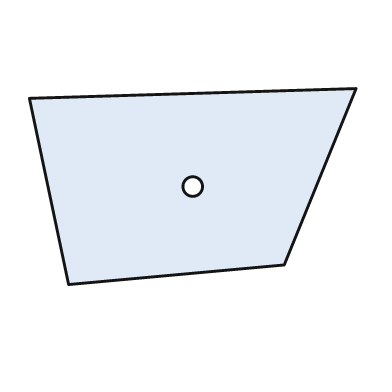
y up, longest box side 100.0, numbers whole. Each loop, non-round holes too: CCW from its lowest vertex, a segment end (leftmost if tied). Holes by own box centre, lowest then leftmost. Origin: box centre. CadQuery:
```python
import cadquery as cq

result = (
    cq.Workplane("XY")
    .moveTo(-38.0, -30.0)
    .lineTo(28.0, -24.0)
    .lineTo(50.0, 30.0)
    .lineTo(-50.0, 27.0)
    .close()
    .moveTo(0.0, 0.0)
    .circle(3.0)
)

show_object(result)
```